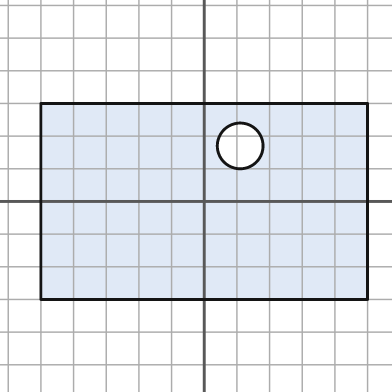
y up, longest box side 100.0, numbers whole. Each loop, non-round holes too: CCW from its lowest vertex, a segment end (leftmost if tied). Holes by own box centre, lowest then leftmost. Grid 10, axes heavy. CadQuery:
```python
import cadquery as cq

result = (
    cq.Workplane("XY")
    .moveTo(-50.0, -30.0)
    .lineTo(50.0, -30.0)
    .lineTo(50.0, 30.0)
    .lineTo(-50.0, 30.0)
    .close()
    .moveTo(11.0, 17.0)
    .circle(7.0)
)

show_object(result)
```